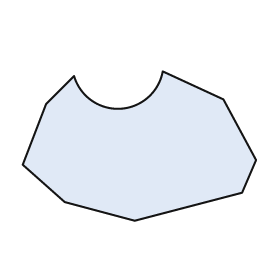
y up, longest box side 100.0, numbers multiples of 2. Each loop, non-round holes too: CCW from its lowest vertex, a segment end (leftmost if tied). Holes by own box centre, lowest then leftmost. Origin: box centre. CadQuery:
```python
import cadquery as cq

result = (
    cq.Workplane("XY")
    .moveTo(-2.0, -32.0)
    .lineTo(44.0, -20.0)
    .lineTo(50.0, -6.0)
    .lineTo(36.0, 20.0)
    .lineTo(10.0, 32.0)
    .threePointArc((-8.0, 16.0), (-28.0, 30.0))
    .lineTo(-40.0, 18.0)
    .lineTo(-50.0, -8.0)
    .lineTo(-32.0, -24.0)
    .close()
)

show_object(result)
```